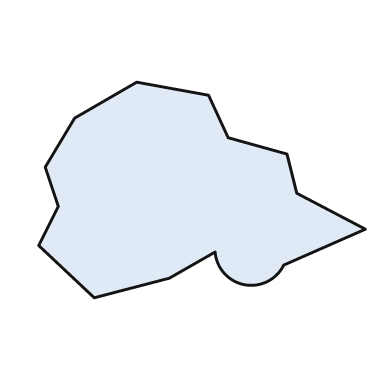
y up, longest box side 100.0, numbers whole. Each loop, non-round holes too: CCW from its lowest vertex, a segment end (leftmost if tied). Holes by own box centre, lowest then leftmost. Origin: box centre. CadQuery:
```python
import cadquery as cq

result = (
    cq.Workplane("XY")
    .moveTo(-33.0, -33.0)
    .lineTo(-10.0, -27.0)
    .lineTo(4.0, -19.0)
    .threePointArc((13.0, -29.0), (25.0, -23.0))
    .lineTo(50.0, -12.0)
    .lineTo(29.0, -1.0)
    .lineTo(26.0, 11.0)
    .lineTo(8.0, 16.0)
    .lineTo(2.0, 29.0)
    .lineTo(-20.0, 33.0)
    .lineTo(-39.0, 22.0)
    .lineTo(-48.0, 7.0)
    .lineTo(-44.0, -5.0)
    .lineTo(-50.0, -17.0)
    .close()
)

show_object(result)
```